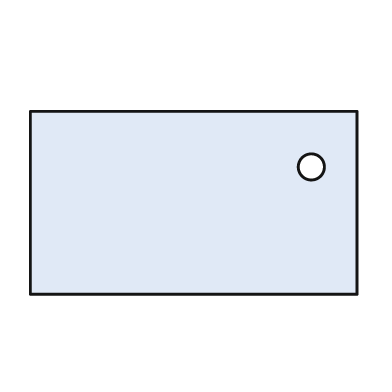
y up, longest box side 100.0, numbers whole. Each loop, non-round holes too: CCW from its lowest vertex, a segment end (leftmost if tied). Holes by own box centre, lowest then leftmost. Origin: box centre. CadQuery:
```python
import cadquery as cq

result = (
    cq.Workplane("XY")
    .moveTo(-50.0, -28.0)
    .lineTo(50.0, -28.0)
    .lineTo(50.0, 28.0)
    .lineTo(-50.0, 28.0)
    .close()
    .moveTo(36.0, 11.0)
    .circle(4.0)
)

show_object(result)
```